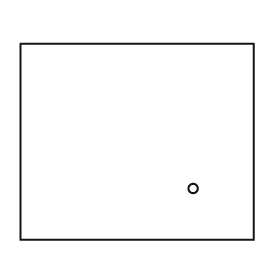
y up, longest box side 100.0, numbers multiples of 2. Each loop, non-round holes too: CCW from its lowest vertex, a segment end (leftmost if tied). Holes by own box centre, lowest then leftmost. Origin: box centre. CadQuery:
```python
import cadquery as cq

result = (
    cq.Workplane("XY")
    .moveTo(-50.0, -42.0)
    .lineTo(50.0, -42.0)
    .lineTo(50.0, 42.0)
    .lineTo(-50.0, 42.0)
    .close()
    .moveTo(24.0, -20.0)
    .circle(2.0)
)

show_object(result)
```